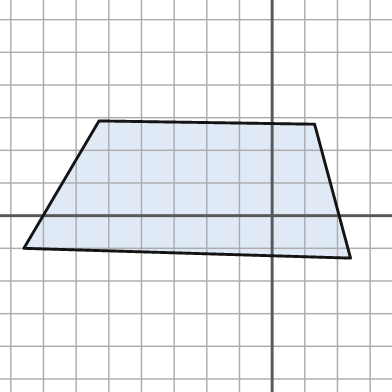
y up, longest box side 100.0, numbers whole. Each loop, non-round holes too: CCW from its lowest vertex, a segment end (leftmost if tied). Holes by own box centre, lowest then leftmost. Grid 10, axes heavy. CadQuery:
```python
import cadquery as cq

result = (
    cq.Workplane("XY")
    .moveTo(24.0, -13.0)
    .lineTo(13.0, 28.0)
    .lineTo(-53.0, 29.0)
    .lineTo(-76.0, -10.0)
    .close()
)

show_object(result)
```